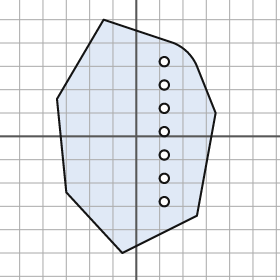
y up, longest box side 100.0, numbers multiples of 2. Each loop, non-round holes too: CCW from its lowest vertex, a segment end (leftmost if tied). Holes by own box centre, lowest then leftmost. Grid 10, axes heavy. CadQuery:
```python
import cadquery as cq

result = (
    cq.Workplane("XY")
    .moveTo(-6.0, -50.0)
    .lineTo(26.0, -34.0)
    .lineTo(34.0, 10.0)
    .lineTo(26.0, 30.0)
    .threePointArc((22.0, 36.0), (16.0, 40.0))
    .lineTo(-14.0, 50.0)
    .lineTo(-34.0, 16.0)
    .lineTo(-30.0, -24.0)
    .close()
    .moveTo(12.0, -28.0)
    .circle(2.0)
    .moveTo(12.0, -18.0)
    .circle(2.0)
    .moveTo(12.0, -8.0)
    .circle(2.0)
    .moveTo(12.0, 2.0)
    .circle(2.0)
    .moveTo(12.0, 12.0)
    .circle(2.0)
    .moveTo(12.0, 22.0)
    .circle(2.0)
    .moveTo(12.0, 32.0)
    .circle(2.0)
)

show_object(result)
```